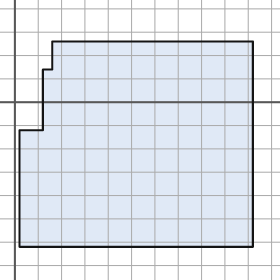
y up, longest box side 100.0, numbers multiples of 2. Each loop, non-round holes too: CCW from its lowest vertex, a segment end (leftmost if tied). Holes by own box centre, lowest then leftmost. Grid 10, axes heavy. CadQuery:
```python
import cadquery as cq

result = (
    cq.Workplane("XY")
    .moveTo(2.0, -62.0)
    .lineTo(102.0, -62.0)
    .lineTo(102.0, 26.0)
    .lineTo(16.0, 26.0)
    .lineTo(16.0, 14.0)
    .lineTo(12.0, 14.0)
    .lineTo(12.0, -12.0)
    .lineTo(2.0, -12.0)
    .close()
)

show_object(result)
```